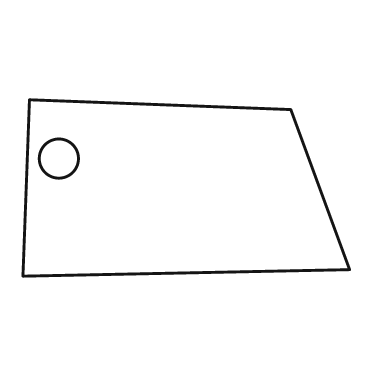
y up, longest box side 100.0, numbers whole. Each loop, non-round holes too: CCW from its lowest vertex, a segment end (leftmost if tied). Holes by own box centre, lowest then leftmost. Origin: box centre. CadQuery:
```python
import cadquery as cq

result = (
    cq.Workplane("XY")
    .moveTo(-50.0, -27.0)
    .lineTo(50.0, -25.0)
    .lineTo(32.0, 24.0)
    .lineTo(-48.0, 27.0)
    .close()
    .moveTo(-39.0, 9.0)
    .circle(6.0)
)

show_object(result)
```